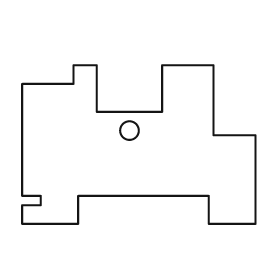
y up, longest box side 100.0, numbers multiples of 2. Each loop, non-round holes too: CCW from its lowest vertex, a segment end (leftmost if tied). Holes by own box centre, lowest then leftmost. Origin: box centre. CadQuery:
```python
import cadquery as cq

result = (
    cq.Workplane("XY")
    .moveTo(-50.0, -34.0)
    .lineTo(-26.0, -34.0)
    .lineTo(-26.0, -22.0)
    .lineTo(30.0, -22.0)
    .lineTo(30.0, -34.0)
    .lineTo(50.0, -34.0)
    .lineTo(50.0, 4.0)
    .lineTo(32.0, 4.0)
    .lineTo(32.0, 34.0)
    .lineTo(10.0, 34.0)
    .lineTo(10.0, 14.0)
    .lineTo(-18.0, 14.0)
    .lineTo(-18.0, 34.0)
    .lineTo(-28.0, 34.0)
    .lineTo(-28.0, 26.0)
    .lineTo(-50.0, 26.0)
    .lineTo(-50.0, -22.0)
    .lineTo(-42.0, -22.0)
    .lineTo(-42.0, -26.0)
    .lineTo(-50.0, -26.0)
    .close()
    .moveTo(-4.0, 6.0)
    .circle(4.0)
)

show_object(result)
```